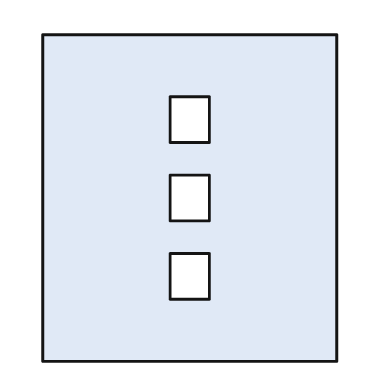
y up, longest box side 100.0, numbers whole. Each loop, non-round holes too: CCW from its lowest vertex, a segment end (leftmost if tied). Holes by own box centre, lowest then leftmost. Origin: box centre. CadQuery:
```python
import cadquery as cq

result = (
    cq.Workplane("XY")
    .moveTo(-45.0, -50.0)
    .lineTo(45.0, -50.0)
    .lineTo(45.0, 50.0)
    .lineTo(-45.0, 50.0)
    .close()
    .moveTo(-6.0, -31.0)
    .lineTo(6.0, -31.0)
    .lineTo(6.0, -17.0)
    .lineTo(-6.0, -17.0)
    .close()
    .moveTo(-6.0, -7.0)
    .lineTo(6.0, -7.0)
    .lineTo(6.0, 7.0)
    .lineTo(-6.0, 7.0)
    .close()
    .moveTo(-6.0, 17.0)
    .lineTo(6.0, 17.0)
    .lineTo(6.0, 31.0)
    .lineTo(-6.0, 31.0)
    .close()
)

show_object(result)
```